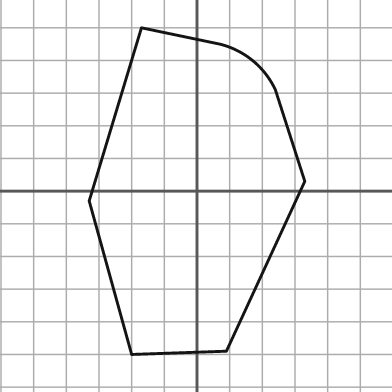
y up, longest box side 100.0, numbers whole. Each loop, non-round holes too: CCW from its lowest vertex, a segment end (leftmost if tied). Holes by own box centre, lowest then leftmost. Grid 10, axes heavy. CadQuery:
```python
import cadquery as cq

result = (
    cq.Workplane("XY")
    .moveTo(-20.0, -50.0)
    .lineTo(9.0, -49.0)
    .lineTo(33.0, 3.0)
    .lineTo(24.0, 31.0)
    .threePointArc((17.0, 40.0), (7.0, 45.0))
    .lineTo(-17.0, 50.0)
    .lineTo(-33.0, -3.0)
    .close()
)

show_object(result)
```